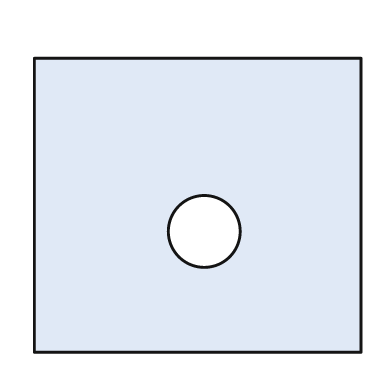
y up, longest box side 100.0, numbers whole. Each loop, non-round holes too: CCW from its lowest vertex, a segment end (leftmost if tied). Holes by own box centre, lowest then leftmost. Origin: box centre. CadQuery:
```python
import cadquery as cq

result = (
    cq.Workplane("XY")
    .moveTo(-50.0, -45.0)
    .lineTo(50.0, -45.0)
    .lineTo(50.0, 45.0)
    .lineTo(-50.0, 45.0)
    .close()
    .moveTo(2.0, -8.0)
    .circle(11.0)
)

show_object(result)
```